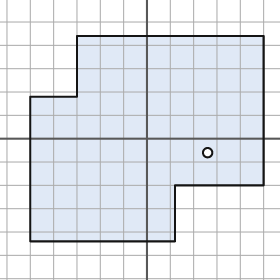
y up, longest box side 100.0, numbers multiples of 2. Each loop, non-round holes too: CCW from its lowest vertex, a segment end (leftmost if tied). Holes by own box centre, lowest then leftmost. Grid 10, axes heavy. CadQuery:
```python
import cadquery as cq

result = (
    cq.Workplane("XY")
    .moveTo(-50.0, -44.0)
    .lineTo(12.0, -44.0)
    .lineTo(12.0, -20.0)
    .lineTo(50.0, -20.0)
    .lineTo(50.0, 44.0)
    .lineTo(-30.0, 44.0)
    .lineTo(-30.0, 18.0)
    .lineTo(-50.0, 18.0)
    .close()
    .moveTo(26.0, -6.0)
    .circle(2.0)
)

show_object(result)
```